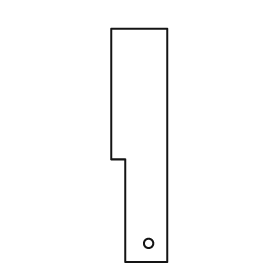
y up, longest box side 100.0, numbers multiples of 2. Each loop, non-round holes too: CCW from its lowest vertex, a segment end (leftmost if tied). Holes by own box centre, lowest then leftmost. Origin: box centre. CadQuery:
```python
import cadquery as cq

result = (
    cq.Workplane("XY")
    .moveTo(-6.0, -50.0)
    .lineTo(12.0, -50.0)
    .lineTo(12.0, 50.0)
    .lineTo(-12.0, 50.0)
    .lineTo(-12.0, -6.0)
    .lineTo(-6.0, -6.0)
    .close()
    .moveTo(4.0, -42.0)
    .circle(2.0)
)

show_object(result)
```